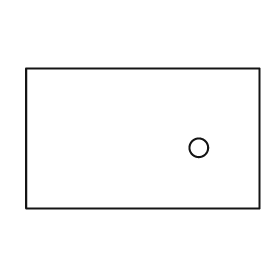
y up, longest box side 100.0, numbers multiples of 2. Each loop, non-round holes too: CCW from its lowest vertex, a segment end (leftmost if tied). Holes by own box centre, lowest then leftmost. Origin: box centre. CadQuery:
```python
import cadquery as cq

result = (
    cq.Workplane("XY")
    .moveTo(-50.0, -30.0)
    .lineTo(50.0, -30.0)
    .lineTo(50.0, 30.0)
    .lineTo(-50.0, 30.0)
    .close()
    .moveTo(24.0, -4.0)
    .circle(4.0)
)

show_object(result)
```